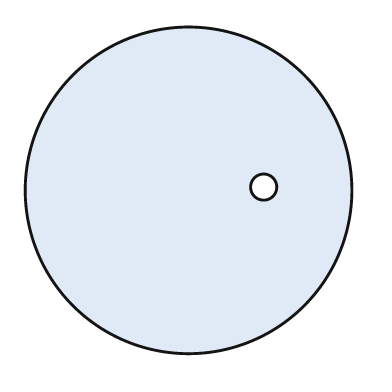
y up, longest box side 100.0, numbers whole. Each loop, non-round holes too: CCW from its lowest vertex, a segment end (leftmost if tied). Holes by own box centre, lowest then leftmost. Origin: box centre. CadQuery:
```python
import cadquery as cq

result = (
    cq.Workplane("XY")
    .moveTo(0.0, 0.0)
    .circle(50.0)
    .moveTo(23.0, 1.0)
    .circle(4.0)
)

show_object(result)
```